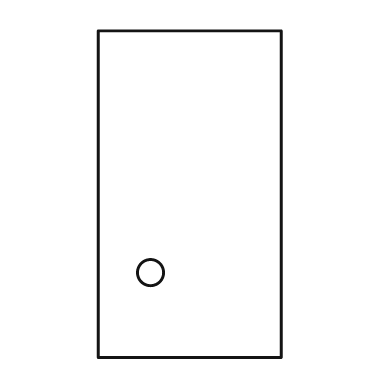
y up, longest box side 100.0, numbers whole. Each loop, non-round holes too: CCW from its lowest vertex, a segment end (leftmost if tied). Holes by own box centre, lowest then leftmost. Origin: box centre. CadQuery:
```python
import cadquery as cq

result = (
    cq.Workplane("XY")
    .moveTo(-28.0, -50.0)
    .lineTo(28.0, -50.0)
    .lineTo(28.0, 50.0)
    .lineTo(-28.0, 50.0)
    .close()
    .moveTo(-12.0, -24.0)
    .circle(4.0)
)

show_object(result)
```